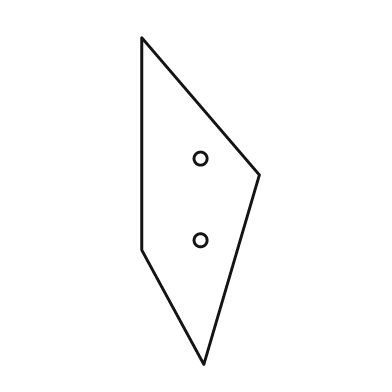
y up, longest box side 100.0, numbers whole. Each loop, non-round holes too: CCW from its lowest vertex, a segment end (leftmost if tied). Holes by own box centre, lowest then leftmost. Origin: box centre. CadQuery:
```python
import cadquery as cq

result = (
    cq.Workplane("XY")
    .moveTo(1.0, -50.0)
    .lineTo(18.0, 8.0)
    .lineTo(-18.0, 50.0)
    .lineTo(-18.0, -15.0)
    .close()
    .moveTo(0.0, -12.0)
    .circle(2.0)
    .moveTo(0.0, 13.0)
    .circle(2.0)
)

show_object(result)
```